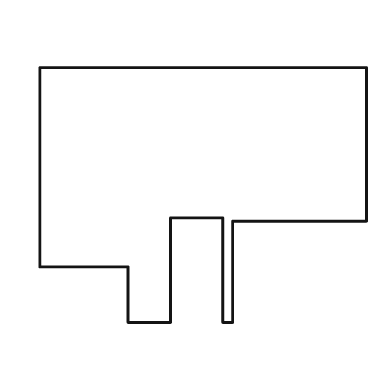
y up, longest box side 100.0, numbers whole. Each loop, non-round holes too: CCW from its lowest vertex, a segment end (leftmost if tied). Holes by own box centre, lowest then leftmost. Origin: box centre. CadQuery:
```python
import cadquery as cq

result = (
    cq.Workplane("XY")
    .moveTo(-23.0, -39.0)
    .lineTo(-10.0, -39.0)
    .lineTo(-10.0, -7.0)
    .lineTo(6.0, -7.0)
    .lineTo(6.0, -39.0)
    .lineTo(9.0, -39.0)
    .lineTo(9.0, -8.0)
    .lineTo(50.0, -8.0)
    .lineTo(50.0, 39.0)
    .lineTo(-50.0, 39.0)
    .lineTo(-50.0, -22.0)
    .lineTo(-23.0, -22.0)
    .close()
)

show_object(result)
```